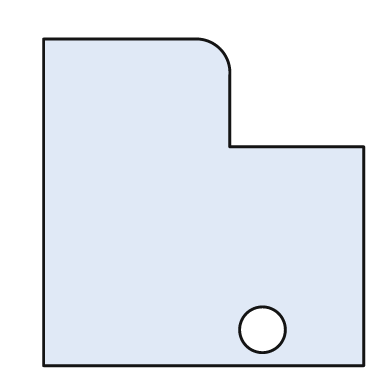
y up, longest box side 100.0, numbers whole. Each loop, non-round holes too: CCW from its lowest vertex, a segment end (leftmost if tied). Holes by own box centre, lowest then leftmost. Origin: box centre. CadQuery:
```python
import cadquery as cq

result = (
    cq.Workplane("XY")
    .moveTo(-49.0, -50.0)
    .lineTo(49.0, -50.0)
    .lineTo(49.0, 17.0)
    .lineTo(8.0, 17.0)
    .lineTo(8.0, 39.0)
    .threePointArc((5.0, 47.0), (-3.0, 50.0))
    .lineTo(-49.0, 50.0)
    .close()
    .moveTo(18.0, -39.0)
    .circle(7.0)
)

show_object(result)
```